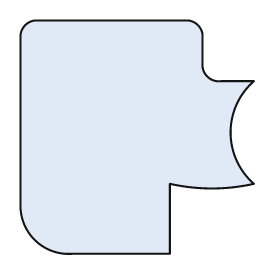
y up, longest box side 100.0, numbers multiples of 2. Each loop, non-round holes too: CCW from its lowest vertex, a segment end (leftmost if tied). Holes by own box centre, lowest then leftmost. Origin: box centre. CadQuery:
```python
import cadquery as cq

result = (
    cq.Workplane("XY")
    .moveTo(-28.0, -50.0)
    .lineTo(14.0, -50.0)
    .lineTo(14.0, -20.0)
    .threePointArc((32.0, -22.0), (50.0, -20.0))
    .threePointArc((40.0, 2.0), (50.0, 24.0))
    .lineTo(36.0, 24.0)
    .threePointArc((30.0, 26.0), (28.0, 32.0))
    .lineTo(28.0, 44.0)
    .threePointArc((26.0, 48.0), (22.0, 50.0))
    .lineTo(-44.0, 50.0)
    .threePointArc((-48.0, 48.0), (-50.0, 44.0))
    .lineTo(-50.0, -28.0)
    .threePointArc((-44.0, -44.0), (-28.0, -50.0))
    .close()
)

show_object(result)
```